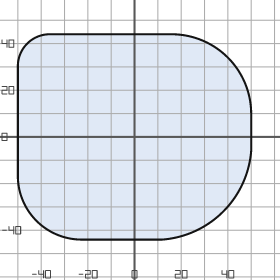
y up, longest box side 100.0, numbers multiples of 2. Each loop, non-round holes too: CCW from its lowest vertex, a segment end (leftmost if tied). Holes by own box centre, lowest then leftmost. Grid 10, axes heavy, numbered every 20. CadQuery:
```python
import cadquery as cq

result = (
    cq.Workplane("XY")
    .moveTo(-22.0, -44.0)
    .lineTo(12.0, -44.0)
    .threePointArc((38.0, -32.0), (50.0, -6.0))
    .lineTo(50.0, 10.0)
    .threePointArc((40.0, 34.0), (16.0, 44.0))
    .lineTo(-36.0, 44.0)
    .threePointArc((-46.0, 40.0), (-50.0, 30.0))
    .lineTo(-50.0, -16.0)
    .threePointArc((-42.0, -36.0), (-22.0, -44.0))
    .close()
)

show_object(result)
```